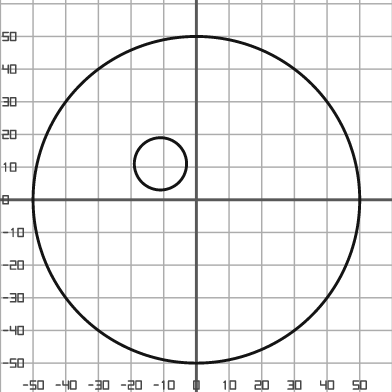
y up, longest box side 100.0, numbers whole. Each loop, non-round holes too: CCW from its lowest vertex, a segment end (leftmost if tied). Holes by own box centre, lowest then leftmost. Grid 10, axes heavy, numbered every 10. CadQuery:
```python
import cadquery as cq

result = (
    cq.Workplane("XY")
    .moveTo(0.0, 0.0)
    .circle(50.0)
    .moveTo(-11.0, 11.0)
    .circle(8.0)
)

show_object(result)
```